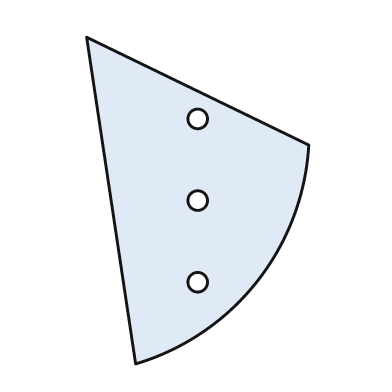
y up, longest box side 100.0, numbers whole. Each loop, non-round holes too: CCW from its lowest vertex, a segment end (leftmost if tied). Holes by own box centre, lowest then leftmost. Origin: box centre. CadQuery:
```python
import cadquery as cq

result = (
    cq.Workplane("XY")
    .moveTo(-19.0, -50.0)
    .threePointArc((18.0, -25.0), (34.0, 17.0))
    .lineTo(-34.0, 50.0)
    .close()
    .moveTo(0.0, -25.0)
    .circle(3.0)
    .moveTo(0.0, 0.0)
    .circle(3.0)
    .moveTo(0.0, 25.0)
    .circle(3.0)
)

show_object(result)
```